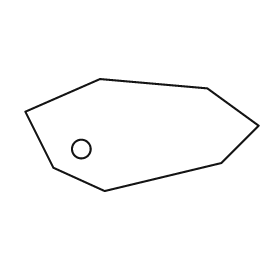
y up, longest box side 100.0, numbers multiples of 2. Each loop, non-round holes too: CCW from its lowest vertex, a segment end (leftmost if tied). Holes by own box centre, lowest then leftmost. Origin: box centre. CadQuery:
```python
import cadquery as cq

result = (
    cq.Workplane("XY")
    .moveTo(-16.0, -24.0)
    .lineTo(34.0, -12.0)
    .lineTo(50.0, 4.0)
    .lineTo(28.0, 20.0)
    .lineTo(-18.0, 24.0)
    .lineTo(-50.0, 10.0)
    .lineTo(-38.0, -14.0)
    .close()
    .moveTo(-26.0, -6.0)
    .circle(4.0)
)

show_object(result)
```